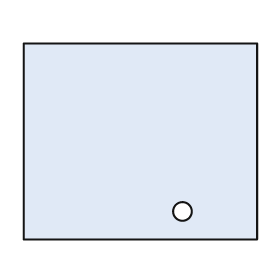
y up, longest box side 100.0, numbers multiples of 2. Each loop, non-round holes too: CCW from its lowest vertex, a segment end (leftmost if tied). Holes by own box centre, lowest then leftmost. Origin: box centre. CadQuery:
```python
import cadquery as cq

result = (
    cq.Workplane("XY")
    .moveTo(-50.0, -42.0)
    .lineTo(50.0, -42.0)
    .lineTo(50.0, 42.0)
    .lineTo(-50.0, 42.0)
    .close()
    .moveTo(18.0, -30.0)
    .circle(4.0)
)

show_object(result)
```